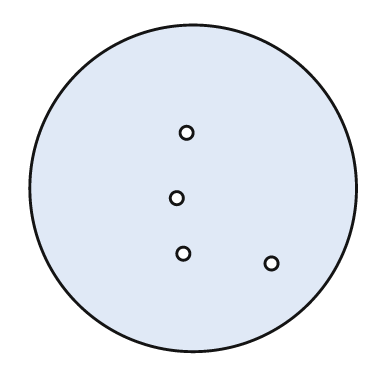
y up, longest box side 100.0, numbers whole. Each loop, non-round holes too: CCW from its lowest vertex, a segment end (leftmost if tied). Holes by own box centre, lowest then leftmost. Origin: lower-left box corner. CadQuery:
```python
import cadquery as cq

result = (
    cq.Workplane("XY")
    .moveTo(50.0, 50.0)
    .circle(50.0)
    .moveTo(74.0, 27.0)
    .circle(2.0)
    .moveTo(47.0, 30.0)
    .circle(2.0)
    .moveTo(45.0, 47.0)
    .circle(2.0)
    .moveTo(48.0, 67.0)
    .circle(2.0)
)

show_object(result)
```